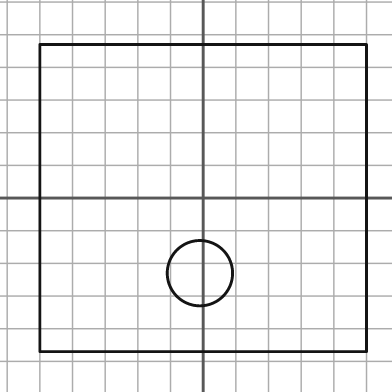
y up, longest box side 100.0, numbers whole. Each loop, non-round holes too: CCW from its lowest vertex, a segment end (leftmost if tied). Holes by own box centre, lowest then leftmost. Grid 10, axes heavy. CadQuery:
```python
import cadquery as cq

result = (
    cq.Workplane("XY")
    .moveTo(-50.0, -47.0)
    .lineTo(50.0, -47.0)
    .lineTo(50.0, 47.0)
    .lineTo(-50.0, 47.0)
    .close()
    .moveTo(-1.0, -23.0)
    .circle(10.0)
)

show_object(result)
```